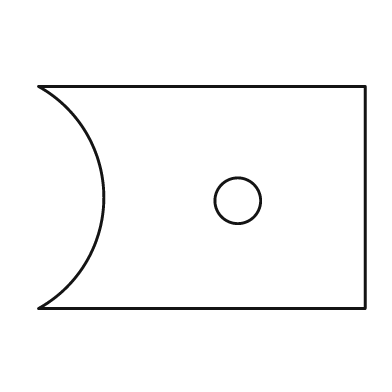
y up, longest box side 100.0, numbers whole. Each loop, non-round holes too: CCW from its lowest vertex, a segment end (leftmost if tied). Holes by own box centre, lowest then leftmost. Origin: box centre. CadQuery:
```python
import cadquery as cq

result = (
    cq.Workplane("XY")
    .moveTo(-50.0, -34.0)
    .lineTo(50.0, -34.0)
    .lineTo(50.0, 34.0)
    .lineTo(-50.0, 34.0)
    .threePointArc((-30.0, 0.0), (-50.0, -34.0))
    .close()
    .moveTo(11.0, -1.0)
    .circle(7.0)
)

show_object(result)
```